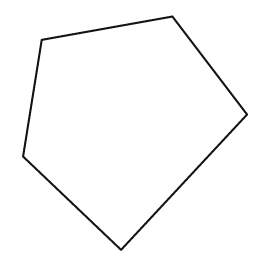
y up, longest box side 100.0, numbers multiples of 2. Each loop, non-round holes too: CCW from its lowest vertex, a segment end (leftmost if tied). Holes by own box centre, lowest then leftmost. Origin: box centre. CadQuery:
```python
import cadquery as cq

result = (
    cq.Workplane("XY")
    .moveTo(-6.0, -50.0)
    .lineTo(48.0, 8.0)
    .lineTo(16.0, 50.0)
    .lineTo(-40.0, 40.0)
    .lineTo(-48.0, -10.0)
    .close()
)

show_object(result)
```